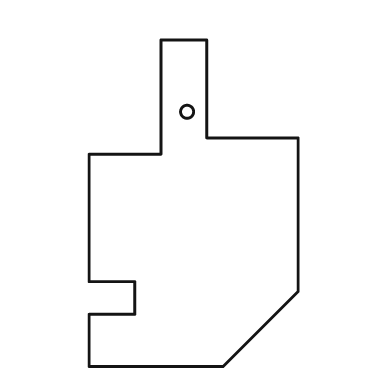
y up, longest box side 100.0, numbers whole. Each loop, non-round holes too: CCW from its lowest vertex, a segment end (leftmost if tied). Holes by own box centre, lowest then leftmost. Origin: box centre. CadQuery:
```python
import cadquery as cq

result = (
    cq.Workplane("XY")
    .moveTo(-32.0, -50.0)
    .lineTo(9.0, -50.0)
    .lineTo(32.0, -27.0)
    .lineTo(32.0, 20.0)
    .lineTo(4.0, 20.0)
    .lineTo(4.0, 50.0)
    .lineTo(-10.0, 50.0)
    .lineTo(-10.0, 15.0)
    .lineTo(-32.0, 15.0)
    .lineTo(-32.0, -24.0)
    .lineTo(-18.0, -24.0)
    .lineTo(-18.0, -34.0)
    .lineTo(-32.0, -34.0)
    .close()
    .moveTo(-2.0, 28.0)
    .circle(2.0)
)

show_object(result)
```